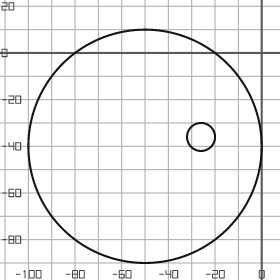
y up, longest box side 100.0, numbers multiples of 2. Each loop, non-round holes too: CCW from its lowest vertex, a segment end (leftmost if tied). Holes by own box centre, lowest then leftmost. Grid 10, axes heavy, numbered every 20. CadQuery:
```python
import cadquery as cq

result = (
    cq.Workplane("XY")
    .moveTo(-50.0, -40.0)
    .circle(50.0)
    .moveTo(-26.0, -36.0)
    .circle(6.0)
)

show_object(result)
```